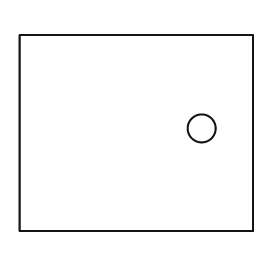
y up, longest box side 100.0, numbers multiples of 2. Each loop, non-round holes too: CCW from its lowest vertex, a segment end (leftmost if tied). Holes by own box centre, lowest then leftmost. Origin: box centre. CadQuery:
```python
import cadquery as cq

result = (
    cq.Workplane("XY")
    .moveTo(-50.0, -42.0)
    .lineTo(50.0, -42.0)
    .lineTo(50.0, 42.0)
    .lineTo(-50.0, 42.0)
    .close()
    .moveTo(28.0, 2.0)
    .circle(6.0)
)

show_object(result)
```